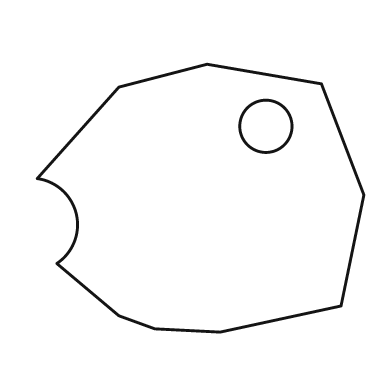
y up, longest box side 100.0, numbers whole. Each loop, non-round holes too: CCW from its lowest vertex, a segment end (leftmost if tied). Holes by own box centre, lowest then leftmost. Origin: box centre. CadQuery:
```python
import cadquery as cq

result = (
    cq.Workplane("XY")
    .moveTo(6.0, -41.0)
    .lineTo(43.0, -33.0)
    .lineTo(50.0, 1.0)
    .lineTo(37.0, 35.0)
    .lineTo(2.0, 41.0)
    .lineTo(-25.0, 34.0)
    .lineTo(-50.0, 6.0)
    .threePointArc((-38.0, -5.0), (-44.0, -20.0))
    .lineTo(-25.0, -36.0)
    .lineTo(-14.0, -40.0)
    .close()
    .moveTo(20.0, 22.0)
    .circle(8.0)
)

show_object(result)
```